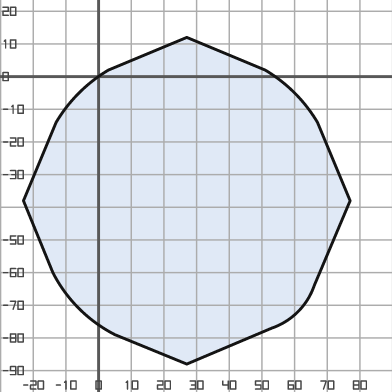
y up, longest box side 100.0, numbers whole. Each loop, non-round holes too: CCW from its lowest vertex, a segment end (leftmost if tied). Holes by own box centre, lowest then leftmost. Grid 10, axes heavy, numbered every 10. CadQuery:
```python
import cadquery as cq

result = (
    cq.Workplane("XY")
    .moveTo(27.0, -88.0)
    .lineTo(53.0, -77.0)
    .threePointArc((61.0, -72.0), (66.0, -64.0))
    .lineTo(77.0, -38.0)
    .lineTo(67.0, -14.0)
    .threePointArc((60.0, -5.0), (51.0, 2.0))
    .lineTo(27.0, 12.0)
    .lineTo(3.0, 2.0)
    .threePointArc((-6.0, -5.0), (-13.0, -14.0))
    .lineTo(-23.0, -38.0)
    .lineTo(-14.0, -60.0)
    .threePointArc((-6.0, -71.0), (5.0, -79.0))
    .close()
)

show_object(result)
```